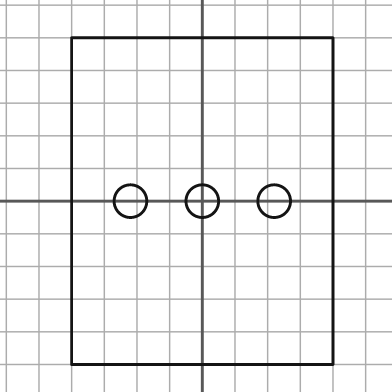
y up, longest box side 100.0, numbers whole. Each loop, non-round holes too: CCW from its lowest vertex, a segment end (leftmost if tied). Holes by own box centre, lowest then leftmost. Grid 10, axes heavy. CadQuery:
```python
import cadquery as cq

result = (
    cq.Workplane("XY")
    .moveTo(-40.0, -50.0)
    .lineTo(40.0, -50.0)
    .lineTo(40.0, 50.0)
    .lineTo(-40.0, 50.0)
    .close()
    .moveTo(-22.0, 0.0)
    .circle(5.0)
    .moveTo(0.0, 0.0)
    .circle(5.0)
    .moveTo(22.0, 0.0)
    .circle(5.0)
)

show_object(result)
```